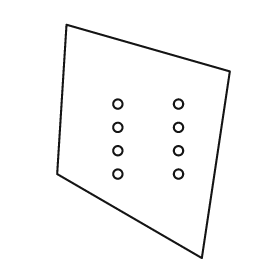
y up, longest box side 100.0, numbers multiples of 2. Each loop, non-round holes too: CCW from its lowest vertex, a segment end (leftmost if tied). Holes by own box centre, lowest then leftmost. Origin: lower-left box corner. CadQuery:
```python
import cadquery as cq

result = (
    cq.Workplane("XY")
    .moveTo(62.0, 0.0)
    .lineTo(74.0, 80.0)
    .lineTo(4.0, 100.0)
    .lineTo(0.0, 36.0)
    .close()
    .moveTo(26.0, 36.0)
    .circle(2.0)
    .moveTo(52.0, 36.0)
    .circle(2.0)
    .moveTo(26.0, 46.0)
    .circle(2.0)
    .moveTo(52.0, 46.0)
    .circle(2.0)
    .moveTo(26.0, 56.0)
    .circle(2.0)
    .moveTo(52.0, 56.0)
    .circle(2.0)
    .moveTo(26.0, 66.0)
    .circle(2.0)
    .moveTo(52.0, 66.0)
    .circle(2.0)
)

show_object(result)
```